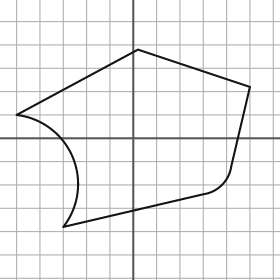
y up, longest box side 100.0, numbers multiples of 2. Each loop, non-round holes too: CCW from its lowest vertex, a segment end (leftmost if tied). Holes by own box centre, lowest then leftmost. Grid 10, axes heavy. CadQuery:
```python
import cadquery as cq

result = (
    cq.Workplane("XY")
    .moveTo(-30.0, -38.0)
    .lineTo(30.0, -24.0)
    .threePointArc((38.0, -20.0), (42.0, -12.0))
    .lineTo(50.0, 22.0)
    .lineTo(2.0, 38.0)
    .lineTo(-50.0, 10.0)
    .threePointArc((-26.0, -8.0), (-30.0, -38.0))
    .close()
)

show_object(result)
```